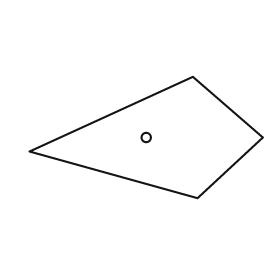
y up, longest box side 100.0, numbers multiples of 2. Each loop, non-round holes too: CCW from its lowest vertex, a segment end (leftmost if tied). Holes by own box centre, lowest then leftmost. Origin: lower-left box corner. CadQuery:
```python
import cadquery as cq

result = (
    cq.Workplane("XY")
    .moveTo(72.0, 0.0)
    .lineTo(100.0, 26.0)
    .lineTo(70.0, 52.0)
    .lineTo(0.0, 20.0)
    .close()
    .moveTo(50.0, 26.0)
    .circle(2.0)
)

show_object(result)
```